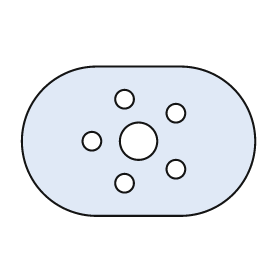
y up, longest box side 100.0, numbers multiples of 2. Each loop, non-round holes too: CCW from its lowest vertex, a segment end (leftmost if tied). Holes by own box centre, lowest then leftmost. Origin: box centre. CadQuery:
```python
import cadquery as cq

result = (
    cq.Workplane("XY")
    .moveTo(-18.0, -32.0)
    .lineTo(18.0, -32.0)
    .threePointArc((50.0, 0.0), (18.0, 32.0))
    .lineTo(-18.0, 32.0)
    .threePointArc((-50.0, 0.0), (-18.0, -32.0))
    .close()
    .moveTo(-6.0, -18.0)
    .circle(4.0)
    .moveTo(16.0, -12.0)
    .circle(4.0)
    .moveTo(-20.0, 0.0)
    .circle(4.0)
    .moveTo(0.0, 0.0)
    .circle(8.0)
    .moveTo(16.0, 12.0)
    .circle(4.0)
    .moveTo(-6.0, 18.0)
    .circle(4.0)
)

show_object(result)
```